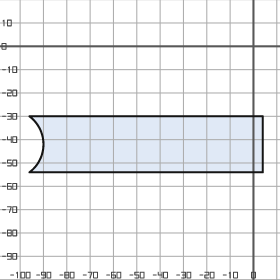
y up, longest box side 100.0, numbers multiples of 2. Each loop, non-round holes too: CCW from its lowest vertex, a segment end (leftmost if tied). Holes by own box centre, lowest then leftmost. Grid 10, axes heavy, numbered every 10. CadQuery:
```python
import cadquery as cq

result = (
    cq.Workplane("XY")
    .moveTo(-96.0, -54.0)
    .lineTo(4.0, -54.0)
    .lineTo(4.0, -30.0)
    .lineTo(-96.0, -30.0)
    .threePointArc((-90.0, -42.0), (-96.0, -54.0))
    .close()
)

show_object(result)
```